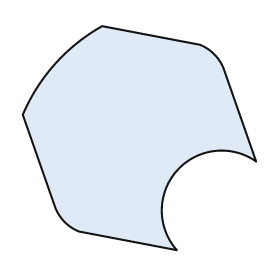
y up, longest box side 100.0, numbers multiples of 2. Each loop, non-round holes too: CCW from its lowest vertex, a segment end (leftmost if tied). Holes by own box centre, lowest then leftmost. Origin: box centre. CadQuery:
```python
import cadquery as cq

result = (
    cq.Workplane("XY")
    .moveTo(16.0, -48.0)
    .threePointArc((16.0, -14.0), (50.0, -10.0))
    .lineTo(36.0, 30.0)
    .threePointArc((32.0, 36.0), (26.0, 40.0))
    .lineTo(-16.0, 48.0)
    .threePointArc((-36.0, 32.0), (-50.0, 10.0))
    .lineTo(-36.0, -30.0)
    .threePointArc((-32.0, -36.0), (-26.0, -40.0))
    .close()
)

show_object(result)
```